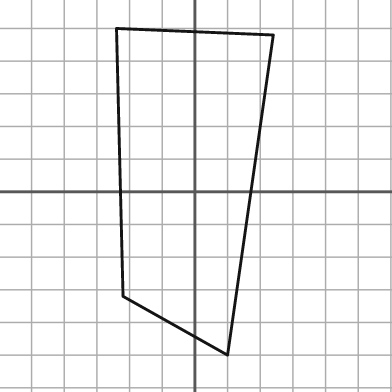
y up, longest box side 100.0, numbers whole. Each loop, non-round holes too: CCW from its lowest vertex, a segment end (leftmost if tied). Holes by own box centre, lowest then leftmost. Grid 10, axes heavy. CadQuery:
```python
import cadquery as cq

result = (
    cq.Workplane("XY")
    .moveTo(10.0, -50.0)
    .lineTo(24.0, 48.0)
    .lineTo(-24.0, 50.0)
    .lineTo(-22.0, -32.0)
    .close()
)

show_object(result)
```